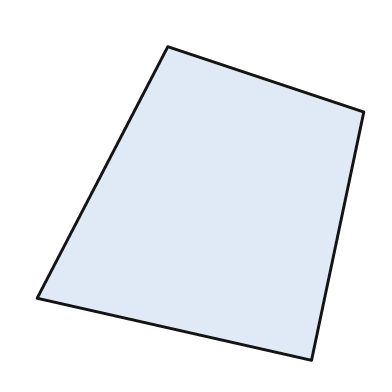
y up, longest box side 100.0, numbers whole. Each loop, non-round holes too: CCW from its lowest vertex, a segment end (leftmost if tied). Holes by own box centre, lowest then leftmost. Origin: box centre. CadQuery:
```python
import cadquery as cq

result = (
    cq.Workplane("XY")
    .moveTo(34.0, -48.0)
    .lineTo(50.0, 28.0)
    .lineTo(-10.0, 48.0)
    .lineTo(-50.0, -29.0)
    .close()
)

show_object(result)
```